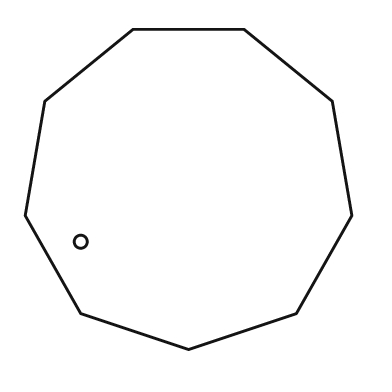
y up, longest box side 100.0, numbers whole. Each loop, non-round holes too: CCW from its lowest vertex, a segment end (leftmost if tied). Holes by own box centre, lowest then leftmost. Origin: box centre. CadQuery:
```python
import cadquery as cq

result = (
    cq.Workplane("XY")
    .moveTo(0.0, -49.0)
    .lineTo(33.0, -38.0)
    .lineTo(50.0, -8.0)
    .lineTo(44.0, 27.0)
    .lineTo(17.0, 49.0)
    .lineTo(-17.0, 49.0)
    .lineTo(-44.0, 27.0)
    .lineTo(-50.0, -8.0)
    .lineTo(-33.0, -38.0)
    .close()
    .moveTo(-33.0, -16.0)
    .circle(2.0)
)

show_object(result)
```